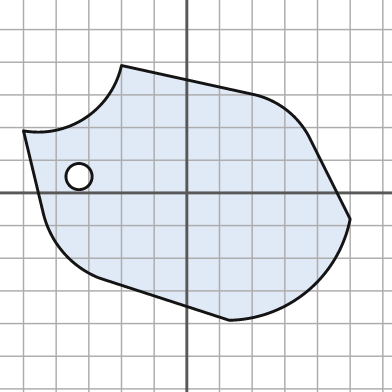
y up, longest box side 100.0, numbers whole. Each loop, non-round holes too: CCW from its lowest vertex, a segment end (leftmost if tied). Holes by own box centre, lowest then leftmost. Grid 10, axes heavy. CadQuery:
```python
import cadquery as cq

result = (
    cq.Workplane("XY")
    .moveTo(13.0, -39.0)
    .threePointArc((37.0, -30.0), (50.0, -8.0))
    .lineTo(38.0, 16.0)
    .threePointArc((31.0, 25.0), (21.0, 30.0))
    .lineTo(-20.0, 39.0)
    .threePointArc((-31.0, 23.0), (-50.0, 19.0))
    .lineTo(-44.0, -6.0)
    .threePointArc((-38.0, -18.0), (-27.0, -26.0))
    .close()
    .moveTo(-33.0, 5.0)
    .circle(4.0)
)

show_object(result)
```